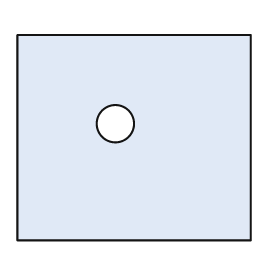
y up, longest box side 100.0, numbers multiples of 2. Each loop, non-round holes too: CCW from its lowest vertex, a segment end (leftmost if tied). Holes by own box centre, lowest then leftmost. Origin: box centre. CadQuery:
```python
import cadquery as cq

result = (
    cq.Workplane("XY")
    .moveTo(-50.0, -44.0)
    .lineTo(50.0, -44.0)
    .lineTo(50.0, 44.0)
    .lineTo(-50.0, 44.0)
    .close()
    .moveTo(-8.0, 6.0)
    .circle(8.0)
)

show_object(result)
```